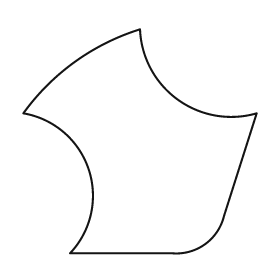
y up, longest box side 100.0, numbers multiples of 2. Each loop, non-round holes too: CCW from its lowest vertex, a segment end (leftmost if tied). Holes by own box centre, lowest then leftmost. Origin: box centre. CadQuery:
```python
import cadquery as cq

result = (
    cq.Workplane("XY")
    .moveTo(-30.0, -48.0)
    .lineTo(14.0, -48.0)
    .threePointArc((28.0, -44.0), (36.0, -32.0))
    .lineTo(50.0, 12.0)
    .threePointArc((16.0, 18.0), (0.0, 48.0))
    .threePointArc((-28.0, 34.0), (-50.0, 12.0))
    .threePointArc((-22.0, -12.0), (-30.0, -48.0))
    .close()
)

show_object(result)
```